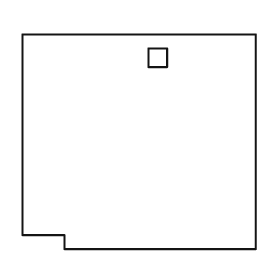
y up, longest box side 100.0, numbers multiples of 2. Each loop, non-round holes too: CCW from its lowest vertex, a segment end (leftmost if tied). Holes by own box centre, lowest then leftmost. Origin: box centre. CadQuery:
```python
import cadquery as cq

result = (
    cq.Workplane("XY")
    .moveTo(-32.0, -46.0)
    .lineTo(50.0, -46.0)
    .lineTo(50.0, 46.0)
    .lineTo(-50.0, 46.0)
    .lineTo(-50.0, -40.0)
    .lineTo(-32.0, -40.0)
    .close()
    .moveTo(4.0, 32.0)
    .lineTo(12.0, 32.0)
    .lineTo(12.0, 40.0)
    .lineTo(4.0, 40.0)
    .close()
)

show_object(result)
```